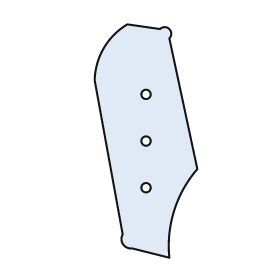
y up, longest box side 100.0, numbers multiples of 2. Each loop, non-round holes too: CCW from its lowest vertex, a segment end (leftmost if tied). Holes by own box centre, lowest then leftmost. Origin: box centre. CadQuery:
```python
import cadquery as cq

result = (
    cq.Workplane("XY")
    .moveTo(10.0, -50.0)
    .threePointArc((12.0, -30.0), (22.0, -12.0))
    .lineTo(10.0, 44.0)
    .threePointArc((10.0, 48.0), (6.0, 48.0))
    .lineTo(-8.0, 50.0)
    .threePointArc((-18.0, 40.0), (-22.0, 26.0))
    .lineTo(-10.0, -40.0)
    .threePointArc((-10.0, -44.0), (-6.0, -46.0))
    .close()
    .moveTo(0.0, -20.0)
    .circle(2.0)
    .moveTo(0.0, 0.0)
    .circle(2.0)
    .moveTo(0.0, 20.0)
    .circle(2.0)
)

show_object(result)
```